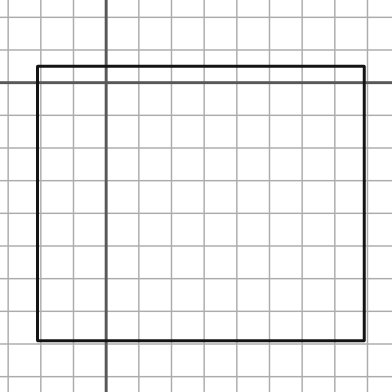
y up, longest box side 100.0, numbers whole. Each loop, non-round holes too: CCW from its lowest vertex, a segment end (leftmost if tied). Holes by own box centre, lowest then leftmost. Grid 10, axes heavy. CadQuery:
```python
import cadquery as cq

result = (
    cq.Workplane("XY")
    .moveTo(-21.0, -79.0)
    .lineTo(79.0, -79.0)
    .lineTo(79.0, 5.0)
    .lineTo(-21.0, 5.0)
    .close()
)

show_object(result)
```